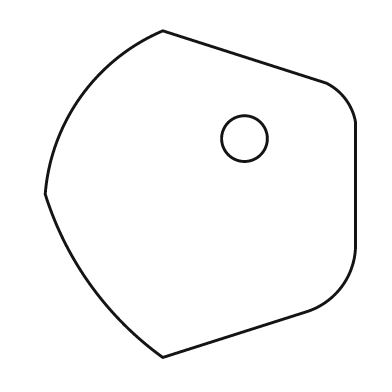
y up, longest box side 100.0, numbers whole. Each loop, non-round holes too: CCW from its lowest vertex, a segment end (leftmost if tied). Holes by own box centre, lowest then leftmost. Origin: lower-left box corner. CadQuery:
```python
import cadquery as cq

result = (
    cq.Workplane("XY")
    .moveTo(36.0, 0.0)
    .lineTo(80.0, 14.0)
    .threePointArc((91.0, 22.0), (95.0, 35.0))
    .lineTo(95.0, 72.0)
    .threePointArc((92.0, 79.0), (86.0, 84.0))
    .lineTo(36.0, 100.0)
    .threePointArc((11.0, 80.0), (0.0, 50.0))
    .threePointArc((14.0, 22.0), (36.0, 0.0))
    .close()
    .moveTo(61.0, 67.0)
    .circle(7.0)
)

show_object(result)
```